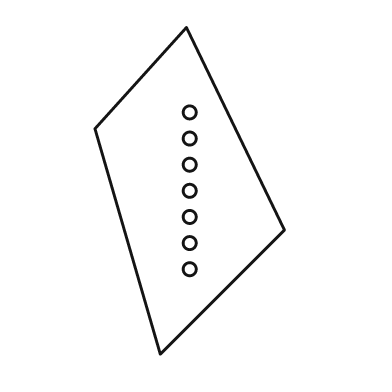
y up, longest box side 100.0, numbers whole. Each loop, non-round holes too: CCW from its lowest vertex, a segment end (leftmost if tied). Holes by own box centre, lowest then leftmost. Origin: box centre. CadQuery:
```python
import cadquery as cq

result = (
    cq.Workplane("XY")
    .moveTo(-9.0, -50.0)
    .lineTo(29.0, -12.0)
    .lineTo(-1.0, 50.0)
    .lineTo(-29.0, 19.0)
    .close()
    .moveTo(0.0, -24.0)
    .circle(2.0)
    .moveTo(0.0, -16.0)
    .circle(2.0)
    .moveTo(0.0, -8.0)
    .circle(2.0)
    .moveTo(0.0, 0.0)
    .circle(2.0)
    .moveTo(0.0, 8.0)
    .circle(2.0)
    .moveTo(0.0, 16.0)
    .circle(2.0)
    .moveTo(0.0, 24.0)
    .circle(2.0)
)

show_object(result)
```